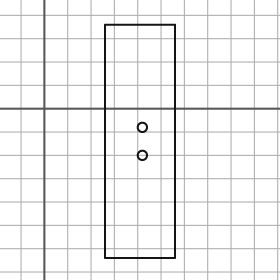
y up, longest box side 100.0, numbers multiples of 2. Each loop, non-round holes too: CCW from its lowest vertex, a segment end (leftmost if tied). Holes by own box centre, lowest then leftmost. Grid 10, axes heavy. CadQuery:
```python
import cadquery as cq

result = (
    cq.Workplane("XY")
    .moveTo(26.0, -64.0)
    .lineTo(56.0, -64.0)
    .lineTo(56.0, 36.0)
    .lineTo(26.0, 36.0)
    .close()
    .moveTo(42.0, -20.0)
    .circle(2.0)
    .moveTo(42.0, -8.0)
    .circle(2.0)
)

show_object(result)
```